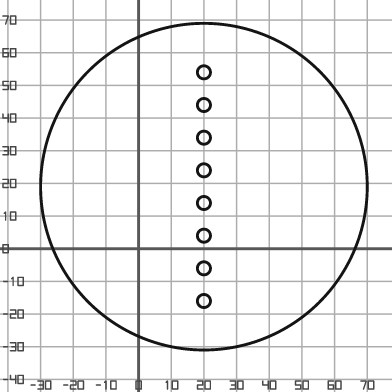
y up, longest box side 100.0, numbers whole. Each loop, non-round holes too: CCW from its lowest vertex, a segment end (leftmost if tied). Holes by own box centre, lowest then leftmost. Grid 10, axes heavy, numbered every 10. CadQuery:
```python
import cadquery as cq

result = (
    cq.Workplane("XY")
    .moveTo(20.0, 19.0)
    .circle(50.0)
    .moveTo(20.0, -16.0)
    .circle(2.0)
    .moveTo(20.0, -6.0)
    .circle(2.0)
    .moveTo(20.0, 4.0)
    .circle(2.0)
    .moveTo(20.0, 14.0)
    .circle(2.0)
    .moveTo(20.0, 24.0)
    .circle(2.0)
    .moveTo(20.0, 34.0)
    .circle(2.0)
    .moveTo(20.0, 44.0)
    .circle(2.0)
    .moveTo(20.0, 54.0)
    .circle(2.0)
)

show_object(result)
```